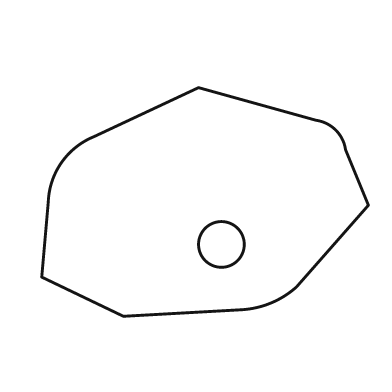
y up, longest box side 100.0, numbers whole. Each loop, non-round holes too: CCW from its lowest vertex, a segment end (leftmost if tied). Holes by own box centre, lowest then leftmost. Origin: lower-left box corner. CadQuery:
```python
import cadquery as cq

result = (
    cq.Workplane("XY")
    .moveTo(25.0, 0.0)
    .lineTo(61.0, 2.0)
    .threePointArc((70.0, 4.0), (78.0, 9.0))
    .lineTo(100.0, 34.0)
    .lineTo(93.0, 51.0)
    .threePointArc((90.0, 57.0), (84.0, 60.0))
    .lineTo(48.0, 70.0)
    .lineTo(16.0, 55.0)
    .threePointArc((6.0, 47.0), (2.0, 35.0))
    .lineTo(0.0, 12.0)
    .close()
    .moveTo(55.0, 22.0)
    .circle(7.0)
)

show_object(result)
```